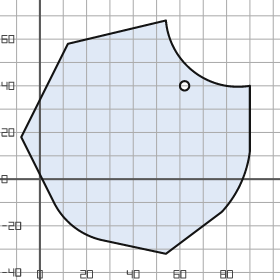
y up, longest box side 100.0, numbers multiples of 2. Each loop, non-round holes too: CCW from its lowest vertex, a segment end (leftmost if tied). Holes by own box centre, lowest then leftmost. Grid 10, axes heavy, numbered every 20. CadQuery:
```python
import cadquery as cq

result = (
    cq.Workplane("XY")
    .moveTo(54.0, -32.0)
    .lineTo(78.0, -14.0)
    .threePointArc((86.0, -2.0), (90.0, 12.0))
    .lineTo(90.0, 40.0)
    .threePointArc((66.0, 46.0), (54.0, 68.0))
    .lineTo(12.0, 58.0)
    .lineTo(-8.0, 18.0)
    .lineTo(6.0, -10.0)
    .threePointArc((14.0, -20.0), (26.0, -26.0))
    .close()
    .moveTo(62.0, 40.0)
    .circle(2.0)
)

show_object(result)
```